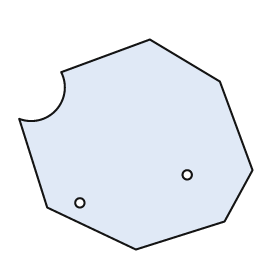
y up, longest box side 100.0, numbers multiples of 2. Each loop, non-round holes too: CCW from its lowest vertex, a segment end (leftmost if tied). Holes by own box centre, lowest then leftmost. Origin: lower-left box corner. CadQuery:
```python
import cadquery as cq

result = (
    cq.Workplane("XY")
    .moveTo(50.0, 0.0)
    .lineTo(88.0, 12.0)
    .lineTo(100.0, 34.0)
    .lineTo(86.0, 72.0)
    .lineTo(56.0, 90.0)
    .lineTo(18.0, 76.0)
    .threePointArc((16.0, 60.0), (0.0, 56.0))
    .lineTo(12.0, 18.0)
    .close()
    .moveTo(26.0, 20.0)
    .circle(2.0)
    .moveTo(72.0, 32.0)
    .circle(2.0)
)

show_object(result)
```